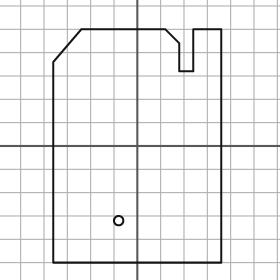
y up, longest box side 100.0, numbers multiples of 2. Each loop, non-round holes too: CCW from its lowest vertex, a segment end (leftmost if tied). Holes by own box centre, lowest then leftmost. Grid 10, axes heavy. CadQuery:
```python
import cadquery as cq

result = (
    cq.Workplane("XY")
    .moveTo(-36.0, -50.0)
    .lineTo(36.0, -50.0)
    .lineTo(36.0, 50.0)
    .lineTo(24.0, 50.0)
    .lineTo(24.0, 32.0)
    .lineTo(18.0, 32.0)
    .lineTo(18.0, 44.0)
    .lineTo(12.0, 50.0)
    .lineTo(-24.0, 50.0)
    .lineTo(-36.0, 36.0)
    .close()
    .moveTo(-8.0, -32.0)
    .circle(2.0)
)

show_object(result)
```